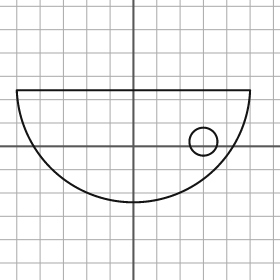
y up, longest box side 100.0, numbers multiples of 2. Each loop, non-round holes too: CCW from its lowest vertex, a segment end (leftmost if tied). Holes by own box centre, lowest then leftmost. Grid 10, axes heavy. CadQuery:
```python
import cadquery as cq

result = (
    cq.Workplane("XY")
    .moveTo(-50.0, 24.0)
    .threePointArc((0.0, -24.0), (50.0, 24.0))
    .close()
    .moveTo(30.0, 2.0)
    .circle(6.0)
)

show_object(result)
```